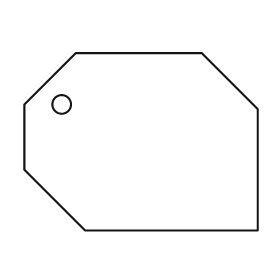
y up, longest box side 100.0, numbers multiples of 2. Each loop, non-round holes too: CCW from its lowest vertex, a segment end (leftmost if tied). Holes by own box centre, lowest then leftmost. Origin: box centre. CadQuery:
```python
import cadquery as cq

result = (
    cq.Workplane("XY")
    .moveTo(-24.0, -38.0)
    .lineTo(50.0, -38.0)
    .lineTo(50.0, 14.0)
    .lineTo(26.0, 38.0)
    .lineTo(-28.0, 38.0)
    .lineTo(-50.0, 16.0)
    .lineTo(-50.0, -12.0)
    .close()
    .moveTo(-34.0, 16.0)
    .circle(4.0)
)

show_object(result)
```